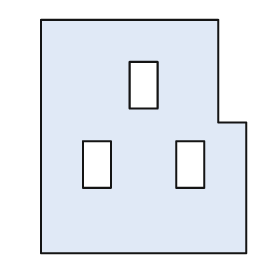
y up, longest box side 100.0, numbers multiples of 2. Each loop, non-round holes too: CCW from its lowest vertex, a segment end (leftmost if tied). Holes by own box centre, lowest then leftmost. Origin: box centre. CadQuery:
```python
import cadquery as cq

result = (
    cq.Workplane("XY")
    .moveTo(-44.0, -50.0)
    .lineTo(44.0, -50.0)
    .lineTo(44.0, 6.0)
    .lineTo(32.0, 6.0)
    .lineTo(32.0, 50.0)
    .lineTo(-44.0, 50.0)
    .close()
    .moveTo(-26.0, -22.0)
    .lineTo(-14.0, -22.0)
    .lineTo(-14.0, -2.0)
    .lineTo(-26.0, -2.0)
    .close()
    .moveTo(14.0, -22.0)
    .lineTo(26.0, -22.0)
    .lineTo(26.0, -2.0)
    .lineTo(14.0, -2.0)
    .close()
    .moveTo(-6.0, 12.0)
    .lineTo(6.0, 12.0)
    .lineTo(6.0, 32.0)
    .lineTo(-6.0, 32.0)
    .close()
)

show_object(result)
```